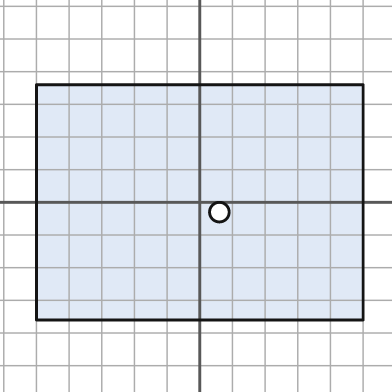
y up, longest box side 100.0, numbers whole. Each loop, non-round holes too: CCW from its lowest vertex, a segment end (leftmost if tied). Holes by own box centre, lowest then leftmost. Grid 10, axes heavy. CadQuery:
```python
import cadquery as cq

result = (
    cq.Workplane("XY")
    .moveTo(-50.0, -36.0)
    .lineTo(50.0, -36.0)
    .lineTo(50.0, 36.0)
    .lineTo(-50.0, 36.0)
    .close()
    .moveTo(6.0, -3.0)
    .circle(3.0)
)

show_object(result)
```